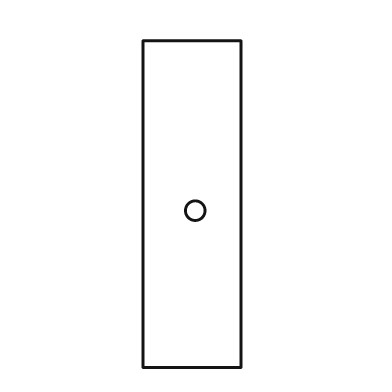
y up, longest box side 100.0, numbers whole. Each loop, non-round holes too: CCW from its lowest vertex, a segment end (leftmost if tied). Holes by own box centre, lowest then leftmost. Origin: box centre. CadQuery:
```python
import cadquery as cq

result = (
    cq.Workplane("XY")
    .moveTo(-15.0, -50.0)
    .lineTo(15.0, -50.0)
    .lineTo(15.0, 50.0)
    .lineTo(-15.0, 50.0)
    .close()
    .moveTo(1.0, -2.0)
    .circle(3.0)
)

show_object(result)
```